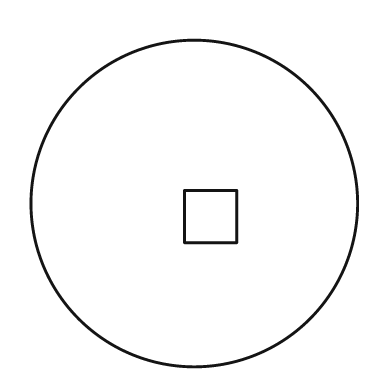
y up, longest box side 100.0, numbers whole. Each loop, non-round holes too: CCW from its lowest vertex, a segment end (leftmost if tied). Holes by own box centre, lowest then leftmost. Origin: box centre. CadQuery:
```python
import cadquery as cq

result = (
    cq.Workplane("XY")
    .moveTo(0.0, 0.0)
    .circle(50.0)
    .moveTo(-3.0, -12.0)
    .lineTo(13.0, -12.0)
    .lineTo(13.0, 4.0)
    .lineTo(-3.0, 4.0)
    .close()
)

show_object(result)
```